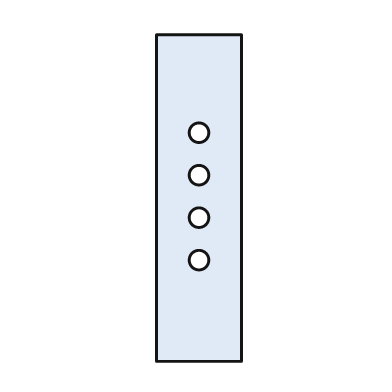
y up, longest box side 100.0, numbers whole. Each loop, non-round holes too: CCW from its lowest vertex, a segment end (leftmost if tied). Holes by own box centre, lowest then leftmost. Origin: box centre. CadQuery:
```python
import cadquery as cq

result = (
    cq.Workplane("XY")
    .moveTo(-13.0, -50.0)
    .lineTo(13.0, -50.0)
    .lineTo(13.0, 50.0)
    .lineTo(-13.0, 50.0)
    .close()
    .moveTo(0.0, -19.0)
    .circle(3.0)
    .moveTo(0.0, -6.0)
    .circle(3.0)
    .moveTo(0.0, 7.0)
    .circle(3.0)
    .moveTo(0.0, 20.0)
    .circle(3.0)
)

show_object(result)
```